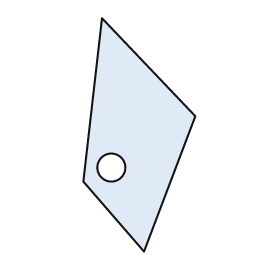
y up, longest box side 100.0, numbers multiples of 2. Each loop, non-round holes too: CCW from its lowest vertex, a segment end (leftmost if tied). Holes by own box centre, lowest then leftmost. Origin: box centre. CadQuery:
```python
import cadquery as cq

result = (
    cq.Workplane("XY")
    .moveTo(2.0, -50.0)
    .lineTo(24.0, 8.0)
    .lineTo(-16.0, 50.0)
    .lineTo(-24.0, -20.0)
    .close()
    .moveTo(-12.0, -14.0)
    .circle(6.0)
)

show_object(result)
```